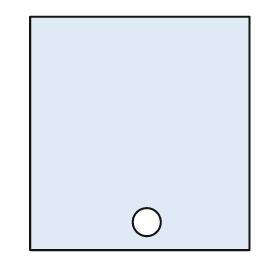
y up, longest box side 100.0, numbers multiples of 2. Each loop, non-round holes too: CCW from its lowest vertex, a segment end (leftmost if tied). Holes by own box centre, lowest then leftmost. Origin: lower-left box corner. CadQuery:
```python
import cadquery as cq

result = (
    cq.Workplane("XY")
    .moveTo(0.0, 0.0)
    .lineTo(94.0, 0.0)
    .lineTo(94.0, 100.0)
    .lineTo(0.0, 100.0)
    .close()
    .moveTo(50.0, 12.0)
    .circle(6.0)
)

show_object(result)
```